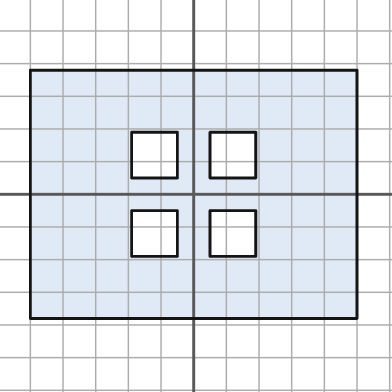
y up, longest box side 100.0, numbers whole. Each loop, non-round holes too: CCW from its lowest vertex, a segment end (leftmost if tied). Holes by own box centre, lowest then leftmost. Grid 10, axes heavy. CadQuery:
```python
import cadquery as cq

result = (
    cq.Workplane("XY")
    .moveTo(-50.0, -38.0)
    .lineTo(50.0, -38.0)
    .lineTo(50.0, 38.0)
    .lineTo(-50.0, 38.0)
    .close()
    .moveTo(-19.0, -19.0)
    .lineTo(-5.0, -19.0)
    .lineTo(-5.0, -5.0)
    .lineTo(-19.0, -5.0)
    .close()
    .moveTo(5.0, -19.0)
    .lineTo(19.0, -19.0)
    .lineTo(19.0, -5.0)
    .lineTo(5.0, -5.0)
    .close()
    .moveTo(-19.0, 5.0)
    .lineTo(-5.0, 5.0)
    .lineTo(-5.0, 19.0)
    .lineTo(-19.0, 19.0)
    .close()
    .moveTo(5.0, 5.0)
    .lineTo(19.0, 5.0)
    .lineTo(19.0, 19.0)
    .lineTo(5.0, 19.0)
    .close()
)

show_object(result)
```